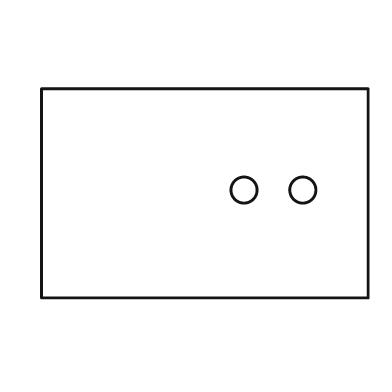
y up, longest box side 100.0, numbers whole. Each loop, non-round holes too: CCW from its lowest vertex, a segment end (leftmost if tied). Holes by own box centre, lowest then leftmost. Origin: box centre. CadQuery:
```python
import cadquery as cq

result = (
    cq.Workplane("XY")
    .moveTo(-50.0, -32.0)
    .lineTo(50.0, -32.0)
    .lineTo(50.0, 32.0)
    .lineTo(-50.0, 32.0)
    .close()
    .moveTo(12.0, 1.0)
    .circle(4.0)
    .moveTo(30.0, 1.0)
    .circle(4.0)
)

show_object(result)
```